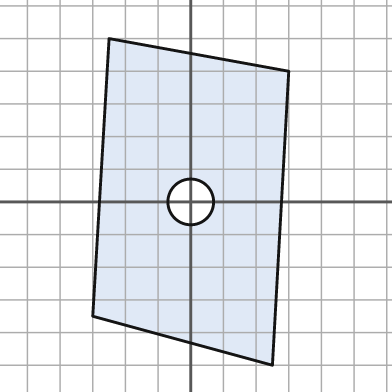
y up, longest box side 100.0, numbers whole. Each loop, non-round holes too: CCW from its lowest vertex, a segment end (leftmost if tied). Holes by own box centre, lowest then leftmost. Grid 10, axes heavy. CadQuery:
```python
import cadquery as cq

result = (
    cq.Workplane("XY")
    .moveTo(25.0, -50.0)
    .lineTo(30.0, 40.0)
    .lineTo(-25.0, 50.0)
    .lineTo(-30.0, -35.0)
    .close()
    .moveTo(0.0, 0.0)
    .circle(7.0)
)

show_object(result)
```